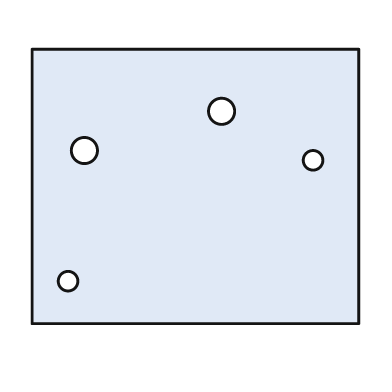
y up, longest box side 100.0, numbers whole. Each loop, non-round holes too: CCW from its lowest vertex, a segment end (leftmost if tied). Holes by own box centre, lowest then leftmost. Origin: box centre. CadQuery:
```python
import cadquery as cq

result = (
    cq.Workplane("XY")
    .moveTo(-50.0, -42.0)
    .lineTo(50.0, -42.0)
    .lineTo(50.0, 42.0)
    .lineTo(-50.0, 42.0)
    .close()
    .moveTo(-39.0, -29.0)
    .circle(3.0)
    .moveTo(36.0, 8.0)
    .circle(3.0)
    .moveTo(-34.0, 11.0)
    .circle(4.0)
    .moveTo(8.0, 23.0)
    .circle(4.0)
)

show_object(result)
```